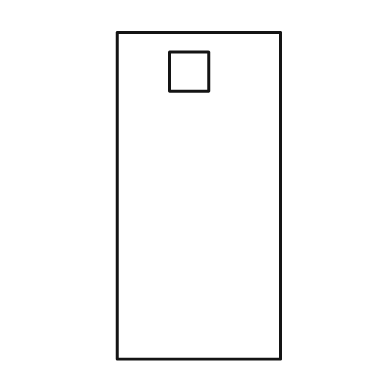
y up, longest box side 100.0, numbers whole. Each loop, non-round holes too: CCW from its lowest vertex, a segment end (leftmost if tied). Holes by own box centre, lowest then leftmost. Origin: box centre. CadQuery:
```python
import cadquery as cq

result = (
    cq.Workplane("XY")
    .moveTo(-25.0, -50.0)
    .lineTo(25.0, -50.0)
    .lineTo(25.0, 50.0)
    .lineTo(-25.0, 50.0)
    .close()
    .moveTo(-9.0, 32.0)
    .lineTo(3.0, 32.0)
    .lineTo(3.0, 44.0)
    .lineTo(-9.0, 44.0)
    .close()
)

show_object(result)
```